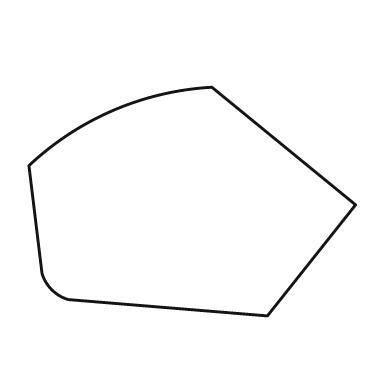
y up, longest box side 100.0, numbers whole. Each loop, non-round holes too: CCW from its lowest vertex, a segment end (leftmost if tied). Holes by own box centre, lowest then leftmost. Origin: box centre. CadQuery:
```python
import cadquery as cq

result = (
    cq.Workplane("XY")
    .moveTo(23.0, -35.0)
    .lineTo(50.0, -1.0)
    .lineTo(6.0, 35.0)
    .threePointArc((-24.0, 28.0), (-50.0, 11.0))
    .lineTo(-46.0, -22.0)
    .threePointArc((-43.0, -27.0), (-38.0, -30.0))
    .close()
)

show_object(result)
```